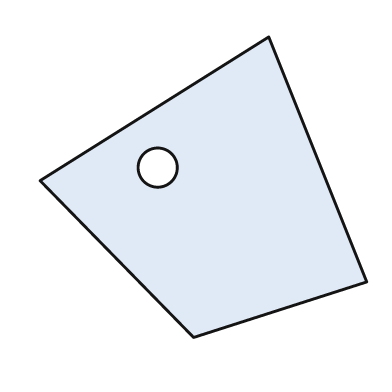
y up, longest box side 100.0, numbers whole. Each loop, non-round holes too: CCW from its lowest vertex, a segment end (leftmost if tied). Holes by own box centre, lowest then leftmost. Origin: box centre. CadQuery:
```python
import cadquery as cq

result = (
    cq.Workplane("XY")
    .moveTo(-3.0, -46.0)
    .lineTo(50.0, -29.0)
    .lineTo(20.0, 46.0)
    .lineTo(-50.0, 2.0)
    .close()
    .moveTo(-14.0, 6.0)
    .circle(6.0)
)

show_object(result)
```